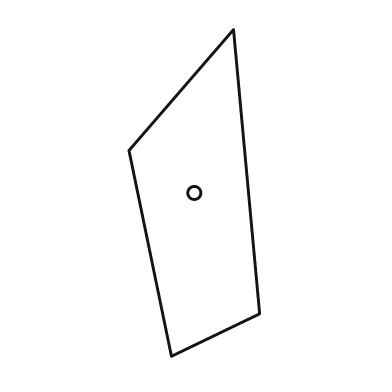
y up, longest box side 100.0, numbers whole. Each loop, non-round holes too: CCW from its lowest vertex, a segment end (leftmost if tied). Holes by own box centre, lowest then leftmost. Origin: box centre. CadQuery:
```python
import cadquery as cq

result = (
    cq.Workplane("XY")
    .moveTo(-7.0, -50.0)
    .lineTo(20.0, -37.0)
    .lineTo(12.0, 50.0)
    .lineTo(-20.0, 13.0)
    .close()
    .moveTo(0.0, 0.0)
    .circle(2.0)
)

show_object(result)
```